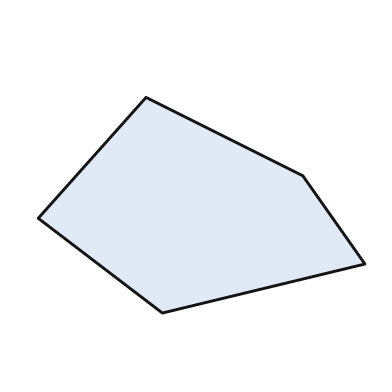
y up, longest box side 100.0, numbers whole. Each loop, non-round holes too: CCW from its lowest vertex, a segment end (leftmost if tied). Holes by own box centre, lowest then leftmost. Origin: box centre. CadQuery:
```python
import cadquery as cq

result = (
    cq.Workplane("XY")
    .moveTo(-12.0, -33.0)
    .lineTo(50.0, -18.0)
    .lineTo(31.0, 9.0)
    .lineTo(-17.0, 33.0)
    .lineTo(-50.0, -4.0)
    .close()
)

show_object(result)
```